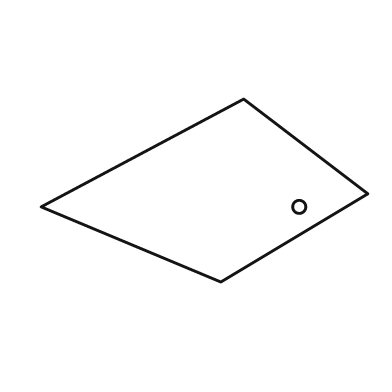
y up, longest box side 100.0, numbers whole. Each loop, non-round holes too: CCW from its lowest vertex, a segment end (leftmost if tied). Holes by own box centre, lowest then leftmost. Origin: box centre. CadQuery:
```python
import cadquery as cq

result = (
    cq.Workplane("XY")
    .moveTo(5.0, -28.0)
    .lineTo(50.0, -1.0)
    .lineTo(12.0, 28.0)
    .lineTo(-50.0, -5.0)
    .close()
    .moveTo(29.0, -5.0)
    .circle(2.0)
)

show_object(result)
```